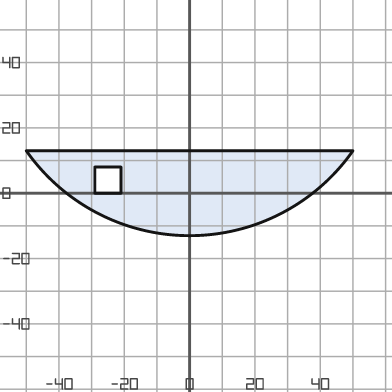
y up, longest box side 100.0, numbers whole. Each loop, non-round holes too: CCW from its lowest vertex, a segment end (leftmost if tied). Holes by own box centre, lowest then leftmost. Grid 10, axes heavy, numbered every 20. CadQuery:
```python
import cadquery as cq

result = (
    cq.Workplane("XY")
    .moveTo(-50.0, 13.0)
    .threePointArc((0.0, -13.0), (50.0, 13.0))
    .close()
    .moveTo(-29.0, 0.0)
    .lineTo(-21.0, 0.0)
    .lineTo(-21.0, 8.0)
    .lineTo(-29.0, 8.0)
    .close()
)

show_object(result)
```